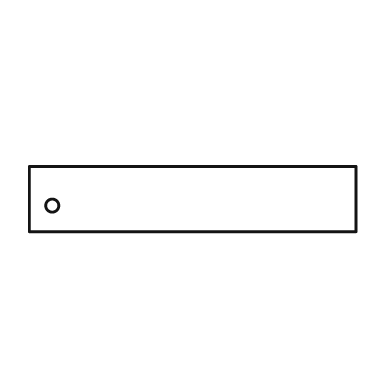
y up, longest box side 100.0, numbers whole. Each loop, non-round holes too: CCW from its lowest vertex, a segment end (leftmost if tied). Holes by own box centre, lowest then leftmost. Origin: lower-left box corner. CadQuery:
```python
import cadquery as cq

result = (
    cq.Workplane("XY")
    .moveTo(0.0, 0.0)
    .lineTo(100.0, 0.0)
    .lineTo(100.0, 20.0)
    .lineTo(0.0, 20.0)
    .close()
    .moveTo(7.0, 8.0)
    .circle(2.0)
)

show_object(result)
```